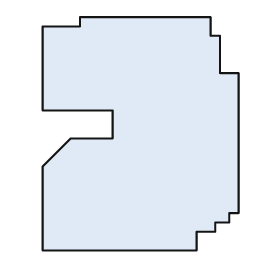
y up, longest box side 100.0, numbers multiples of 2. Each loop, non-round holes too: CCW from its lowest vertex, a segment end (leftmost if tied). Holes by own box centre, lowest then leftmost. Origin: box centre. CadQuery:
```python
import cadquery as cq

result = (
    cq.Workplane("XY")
    .moveTo(-42.0, -50.0)
    .lineTo(24.0, -50.0)
    .lineTo(24.0, -42.0)
    .lineTo(32.0, -42.0)
    .lineTo(32.0, -38.0)
    .lineTo(38.0, -38.0)
    .lineTo(38.0, -34.0)
    .lineTo(42.0, -34.0)
    .lineTo(42.0, 26.0)
    .lineTo(34.0, 26.0)
    .lineTo(34.0, 42.0)
    .lineTo(30.0, 42.0)
    .lineTo(30.0, 50.0)
    .lineTo(-26.0, 50.0)
    .lineTo(-26.0, 46.0)
    .lineTo(-42.0, 46.0)
    .lineTo(-42.0, 10.0)
    .lineTo(-12.0, 10.0)
    .lineTo(-12.0, -2.0)
    .lineTo(-30.0, -2.0)
    .lineTo(-42.0, -14.0)
    .close()
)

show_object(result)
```